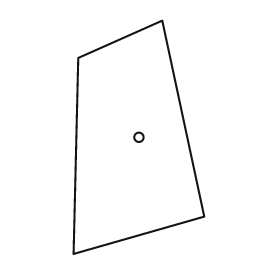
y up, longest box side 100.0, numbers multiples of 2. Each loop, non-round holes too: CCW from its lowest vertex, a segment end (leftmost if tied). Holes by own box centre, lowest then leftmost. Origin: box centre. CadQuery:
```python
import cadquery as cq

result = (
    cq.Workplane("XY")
    .moveTo(-28.0, -50.0)
    .lineTo(28.0, -34.0)
    .lineTo(10.0, 50.0)
    .lineTo(-26.0, 34.0)
    .close()
    .moveTo(0.0, 0.0)
    .circle(2.0)
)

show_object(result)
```